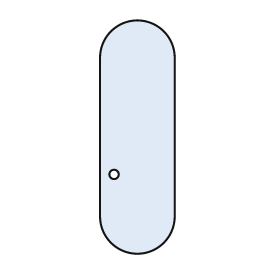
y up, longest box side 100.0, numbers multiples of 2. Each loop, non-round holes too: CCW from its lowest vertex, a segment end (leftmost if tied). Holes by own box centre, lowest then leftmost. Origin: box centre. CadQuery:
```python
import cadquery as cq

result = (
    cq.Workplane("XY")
    .moveTo(-16.0, -34.0)
    .threePointArc((0.0, -50.0), (16.0, -34.0))
    .lineTo(16.0, 34.0)
    .threePointArc((0.0, 50.0), (-16.0, 34.0))
    .close()
    .moveTo(-10.0, -16.0)
    .circle(2.0)
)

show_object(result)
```